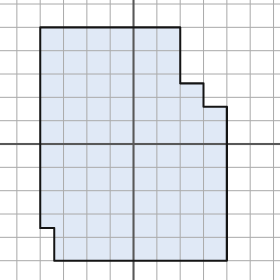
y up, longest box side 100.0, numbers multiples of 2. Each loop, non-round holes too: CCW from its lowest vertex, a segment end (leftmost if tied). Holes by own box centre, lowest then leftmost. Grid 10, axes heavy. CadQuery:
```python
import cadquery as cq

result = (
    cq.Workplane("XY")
    .moveTo(-34.0, -50.0)
    .lineTo(40.0, -50.0)
    .lineTo(40.0, 16.0)
    .lineTo(30.0, 16.0)
    .lineTo(30.0, 26.0)
    .lineTo(20.0, 26.0)
    .lineTo(20.0, 50.0)
    .lineTo(-40.0, 50.0)
    .lineTo(-40.0, -36.0)
    .lineTo(-34.0, -36.0)
    .close()
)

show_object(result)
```